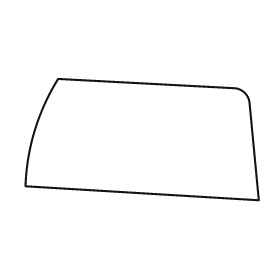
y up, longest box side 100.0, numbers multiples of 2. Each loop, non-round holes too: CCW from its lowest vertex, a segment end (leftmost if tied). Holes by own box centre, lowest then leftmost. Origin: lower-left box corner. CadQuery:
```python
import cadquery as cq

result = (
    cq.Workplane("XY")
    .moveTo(100.0, 0.0)
    .lineTo(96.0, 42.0)
    .threePointArc((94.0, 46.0), (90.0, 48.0))
    .lineTo(14.0, 52.0)
    .threePointArc((4.0, 30.0), (0.0, 6.0))
    .close()
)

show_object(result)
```